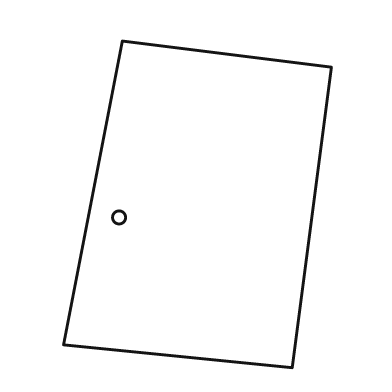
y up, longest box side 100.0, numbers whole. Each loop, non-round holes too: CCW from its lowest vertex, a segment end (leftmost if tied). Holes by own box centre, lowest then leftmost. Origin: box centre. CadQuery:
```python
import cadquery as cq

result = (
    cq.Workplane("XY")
    .moveTo(29.0, -50.0)
    .lineTo(41.0, 42.0)
    .lineTo(-23.0, 50.0)
    .lineTo(-41.0, -43.0)
    .close()
    .moveTo(-24.0, -4.0)
    .circle(2.0)
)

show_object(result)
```